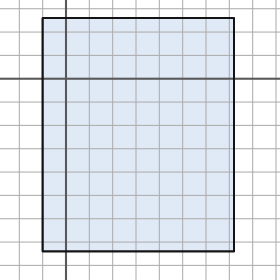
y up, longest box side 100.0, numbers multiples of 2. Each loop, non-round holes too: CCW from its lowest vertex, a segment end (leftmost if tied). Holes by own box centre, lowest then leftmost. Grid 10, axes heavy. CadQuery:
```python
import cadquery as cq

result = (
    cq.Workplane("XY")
    .moveTo(-10.0, -74.0)
    .lineTo(72.0, -74.0)
    .lineTo(72.0, 26.0)
    .lineTo(-10.0, 26.0)
    .close()
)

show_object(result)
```